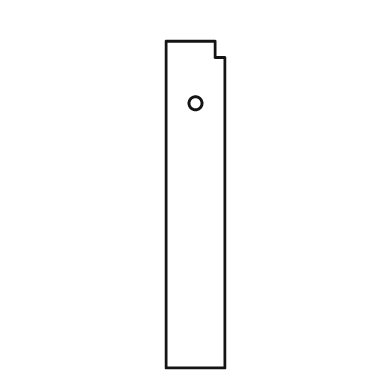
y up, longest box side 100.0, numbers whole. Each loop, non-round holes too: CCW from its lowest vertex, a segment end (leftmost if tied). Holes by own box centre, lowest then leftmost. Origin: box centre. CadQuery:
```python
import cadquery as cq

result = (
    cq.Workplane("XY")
    .moveTo(-9.0, -50.0)
    .lineTo(9.0, -50.0)
    .lineTo(9.0, 45.0)
    .lineTo(6.0, 45.0)
    .lineTo(6.0, 50.0)
    .lineTo(-9.0, 50.0)
    .close()
    .moveTo(0.0, 31.0)
    .circle(2.0)
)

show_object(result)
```